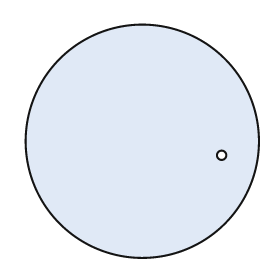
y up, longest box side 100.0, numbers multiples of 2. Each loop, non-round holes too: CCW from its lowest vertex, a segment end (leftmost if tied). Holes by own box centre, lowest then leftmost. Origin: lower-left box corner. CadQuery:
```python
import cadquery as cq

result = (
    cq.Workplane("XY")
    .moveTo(50.0, 50.0)
    .circle(50.0)
    .moveTo(84.0, 44.0)
    .circle(2.0)
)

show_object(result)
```